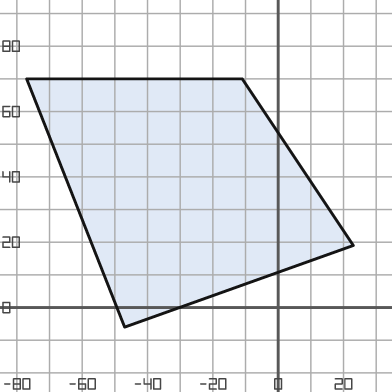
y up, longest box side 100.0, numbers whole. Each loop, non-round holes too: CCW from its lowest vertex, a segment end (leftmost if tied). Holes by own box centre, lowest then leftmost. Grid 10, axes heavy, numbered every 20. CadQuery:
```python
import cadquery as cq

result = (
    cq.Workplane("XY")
    .moveTo(-47.0, -6.0)
    .lineTo(23.0, 19.0)
    .lineTo(-11.0, 70.0)
    .lineTo(-77.0, 70.0)
    .close()
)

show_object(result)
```